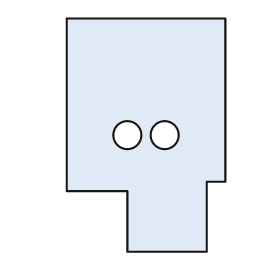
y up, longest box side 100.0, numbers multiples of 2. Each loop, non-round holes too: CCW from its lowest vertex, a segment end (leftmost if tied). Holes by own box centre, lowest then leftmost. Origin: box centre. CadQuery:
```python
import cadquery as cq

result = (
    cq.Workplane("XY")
    .moveTo(-8.0, -50.0)
    .lineTo(26.0, -50.0)
    .lineTo(26.0, -20.0)
    .lineTo(34.0, -20.0)
    .lineTo(34.0, 50.0)
    .lineTo(-34.0, 50.0)
    .lineTo(-34.0, -24.0)
    .lineTo(-8.0, -24.0)
    .close()
    .moveTo(-8.0, 0.0)
    .circle(6.0)
    .moveTo(8.0, 0.0)
    .circle(6.0)
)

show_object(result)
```